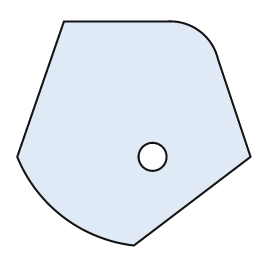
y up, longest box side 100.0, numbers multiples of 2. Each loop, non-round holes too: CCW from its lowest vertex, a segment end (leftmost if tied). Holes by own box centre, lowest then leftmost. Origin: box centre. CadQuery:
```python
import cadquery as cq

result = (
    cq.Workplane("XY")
    .moveTo(0.0, -48.0)
    .lineTo(50.0, -10.0)
    .lineTo(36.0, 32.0)
    .threePointArc((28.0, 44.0), (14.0, 48.0))
    .lineTo(-30.0, 48.0)
    .lineTo(-50.0, -10.0)
    .threePointArc((-30.0, -36.0), (0.0, -48.0))
    .close()
    .moveTo(8.0, -10.0)
    .circle(6.0)
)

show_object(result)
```